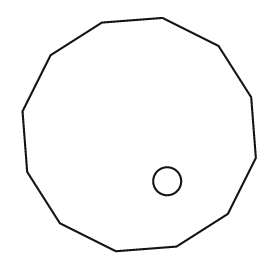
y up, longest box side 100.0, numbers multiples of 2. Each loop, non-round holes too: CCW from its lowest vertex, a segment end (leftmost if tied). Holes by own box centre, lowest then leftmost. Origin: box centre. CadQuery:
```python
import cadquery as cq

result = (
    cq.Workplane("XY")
    .moveTo(-10.0, -50.0)
    .lineTo(16.0, -48.0)
    .lineTo(38.0, -34.0)
    .lineTo(50.0, -10.0)
    .lineTo(48.0, 16.0)
    .lineTo(34.0, 38.0)
    .lineTo(10.0, 50.0)
    .lineTo(-16.0, 48.0)
    .lineTo(-38.0, 34.0)
    .lineTo(-50.0, 10.0)
    .lineTo(-48.0, -16.0)
    .lineTo(-34.0, -38.0)
    .close()
    .moveTo(12.0, -20.0)
    .circle(6.0)
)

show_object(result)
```